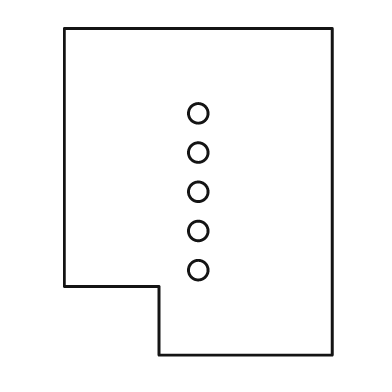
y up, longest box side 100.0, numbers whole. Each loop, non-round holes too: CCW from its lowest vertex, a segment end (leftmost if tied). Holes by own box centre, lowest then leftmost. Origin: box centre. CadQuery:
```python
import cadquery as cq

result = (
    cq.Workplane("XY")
    .moveTo(-12.0, -50.0)
    .lineTo(41.0, -50.0)
    .lineTo(41.0, 50.0)
    .lineTo(-41.0, 50.0)
    .lineTo(-41.0, -29.0)
    .lineTo(-12.0, -29.0)
    .close()
    .moveTo(0.0, -24.0)
    .circle(3.0)
    .moveTo(0.0, -12.0)
    .circle(3.0)
    .moveTo(0.0, 0.0)
    .circle(3.0)
    .moveTo(0.0, 12.0)
    .circle(3.0)
    .moveTo(0.0, 24.0)
    .circle(3.0)
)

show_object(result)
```